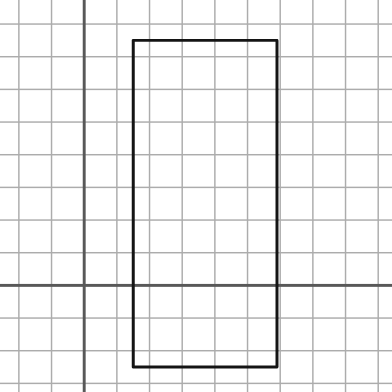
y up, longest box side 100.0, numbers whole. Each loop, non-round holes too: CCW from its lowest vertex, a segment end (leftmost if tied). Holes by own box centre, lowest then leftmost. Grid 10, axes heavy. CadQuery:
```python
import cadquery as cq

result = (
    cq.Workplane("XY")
    .moveTo(15.0, -25.0)
    .lineTo(59.0, -25.0)
    .lineTo(59.0, 75.0)
    .lineTo(15.0, 75.0)
    .close()
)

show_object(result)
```